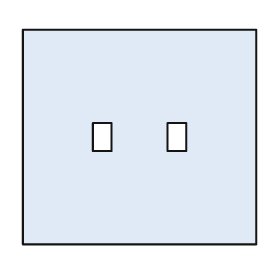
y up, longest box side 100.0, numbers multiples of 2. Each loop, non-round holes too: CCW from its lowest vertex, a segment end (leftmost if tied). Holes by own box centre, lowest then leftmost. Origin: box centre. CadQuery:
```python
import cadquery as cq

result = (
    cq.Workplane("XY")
    .moveTo(-50.0, -46.0)
    .lineTo(50.0, -46.0)
    .lineTo(50.0, 46.0)
    .lineTo(-50.0, 46.0)
    .close()
    .moveTo(-20.0, -6.0)
    .lineTo(-12.0, -6.0)
    .lineTo(-12.0, 6.0)
    .lineTo(-20.0, 6.0)
    .close()
    .moveTo(12.0, -6.0)
    .lineTo(20.0, -6.0)
    .lineTo(20.0, 6.0)
    .lineTo(12.0, 6.0)
    .close()
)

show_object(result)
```